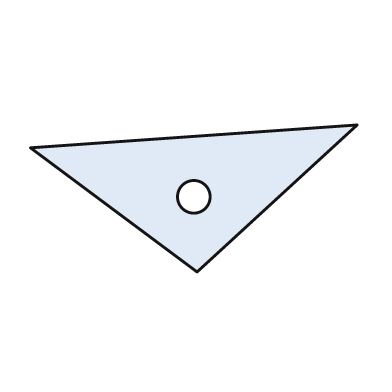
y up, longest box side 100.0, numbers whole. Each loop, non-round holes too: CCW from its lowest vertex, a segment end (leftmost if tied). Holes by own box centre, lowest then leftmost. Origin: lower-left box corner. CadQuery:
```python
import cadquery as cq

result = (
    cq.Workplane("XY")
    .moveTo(51.0, 0.0)
    .lineTo(100.0, 45.0)
    .lineTo(0.0, 38.0)
    .close()
    .moveTo(50.0, 23.0)
    .circle(5.0)
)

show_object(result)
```